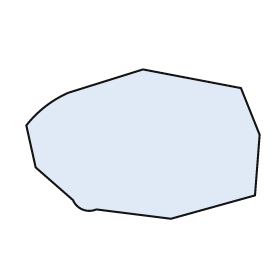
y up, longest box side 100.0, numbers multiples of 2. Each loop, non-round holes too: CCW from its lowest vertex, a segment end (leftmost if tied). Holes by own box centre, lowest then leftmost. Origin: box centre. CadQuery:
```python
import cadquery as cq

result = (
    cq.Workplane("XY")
    .moveTo(12.0, -32.0)
    .lineTo(48.0, -22.0)
    .lineTo(50.0, 4.0)
    .lineTo(42.0, 24.0)
    .lineTo(0.0, 32.0)
    .lineTo(-32.0, 22.0)
    .threePointArc((-42.0, 16.0), (-50.0, 8.0))
    .lineTo(-46.0, -10.0)
    .lineTo(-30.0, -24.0)
    .threePointArc((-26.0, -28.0), (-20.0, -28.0))
    .close()
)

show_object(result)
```